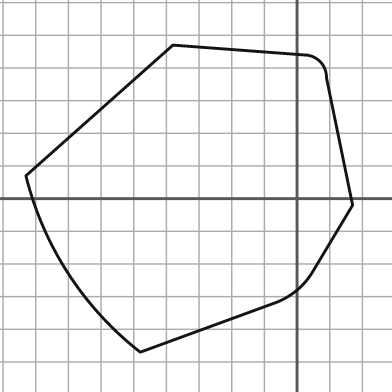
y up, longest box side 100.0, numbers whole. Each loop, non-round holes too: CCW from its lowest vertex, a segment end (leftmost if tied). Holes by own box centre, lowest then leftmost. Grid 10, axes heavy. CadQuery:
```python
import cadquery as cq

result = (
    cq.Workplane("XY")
    .moveTo(-48.0, -47.0)
    .lineTo(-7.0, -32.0)
    .threePointArc((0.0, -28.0), (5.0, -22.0))
    .lineTo(17.0, -2.0)
    .lineTo(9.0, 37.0)
    .threePointArc((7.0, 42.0), (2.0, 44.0))
    .lineTo(-38.0, 47.0)
    .lineTo(-83.0, 7.0)
    .threePointArc((-70.0, -23.0), (-48.0, -47.0))
    .close()
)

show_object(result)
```